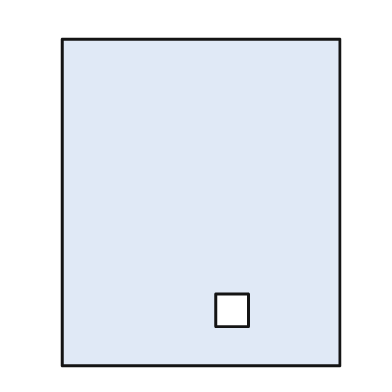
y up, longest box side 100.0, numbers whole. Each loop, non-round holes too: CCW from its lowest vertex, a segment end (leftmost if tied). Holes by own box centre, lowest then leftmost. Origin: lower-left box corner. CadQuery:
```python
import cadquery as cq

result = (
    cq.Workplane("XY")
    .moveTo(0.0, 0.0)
    .lineTo(85.0, 0.0)
    .lineTo(85.0, 100.0)
    .lineTo(0.0, 100.0)
    .close()
    .moveTo(47.0, 12.0)
    .lineTo(57.0, 12.0)
    .lineTo(57.0, 22.0)
    .lineTo(47.0, 22.0)
    .close()
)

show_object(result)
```